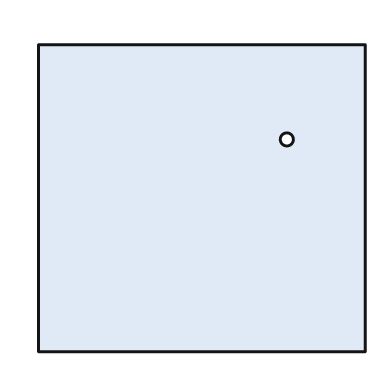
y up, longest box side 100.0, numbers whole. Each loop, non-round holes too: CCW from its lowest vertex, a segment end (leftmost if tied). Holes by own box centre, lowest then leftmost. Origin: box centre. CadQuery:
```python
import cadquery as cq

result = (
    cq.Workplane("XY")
    .moveTo(-50.0, -47.0)
    .lineTo(50.0, -47.0)
    .lineTo(50.0, 47.0)
    .lineTo(-50.0, 47.0)
    .close()
    .moveTo(26.0, 18.0)
    .circle(2.0)
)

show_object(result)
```